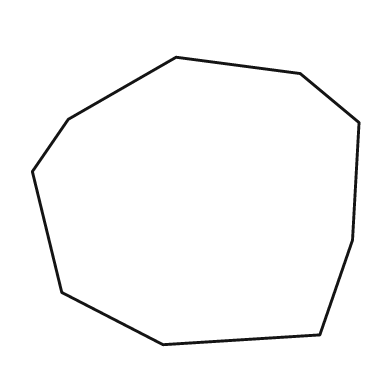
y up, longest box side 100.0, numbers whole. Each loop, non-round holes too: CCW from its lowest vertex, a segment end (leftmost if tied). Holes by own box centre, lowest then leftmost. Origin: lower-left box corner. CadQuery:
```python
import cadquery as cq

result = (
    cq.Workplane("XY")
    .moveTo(40.0, 0.0)
    .lineTo(88.0, 3.0)
    .lineTo(98.0, 32.0)
    .lineTo(100.0, 68.0)
    .lineTo(82.0, 83.0)
    .lineTo(44.0, 88.0)
    .lineTo(11.0, 69.0)
    .lineTo(0.0, 53.0)
    .lineTo(9.0, 16.0)
    .close()
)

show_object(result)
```